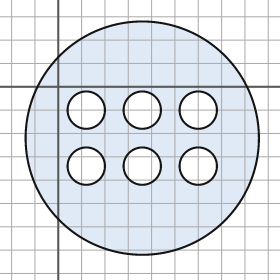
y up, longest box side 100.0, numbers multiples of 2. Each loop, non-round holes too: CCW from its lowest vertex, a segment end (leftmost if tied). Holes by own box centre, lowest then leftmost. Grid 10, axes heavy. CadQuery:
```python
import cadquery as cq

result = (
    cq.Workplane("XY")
    .moveTo(36.0, -22.0)
    .circle(50.0)
    .moveTo(12.0, -34.0)
    .circle(8.0)
    .moveTo(36.0, -34.0)
    .circle(8.0)
    .moveTo(60.0, -34.0)
    .circle(8.0)
    .moveTo(12.0, -10.0)
    .circle(8.0)
    .moveTo(36.0, -10.0)
    .circle(8.0)
    .moveTo(60.0, -10.0)
    .circle(8.0)
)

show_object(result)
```